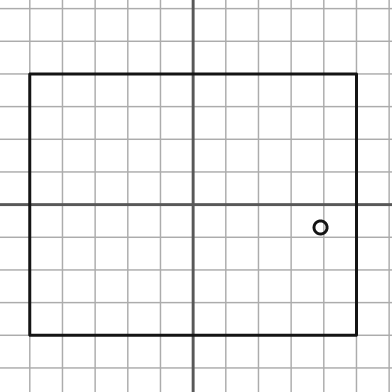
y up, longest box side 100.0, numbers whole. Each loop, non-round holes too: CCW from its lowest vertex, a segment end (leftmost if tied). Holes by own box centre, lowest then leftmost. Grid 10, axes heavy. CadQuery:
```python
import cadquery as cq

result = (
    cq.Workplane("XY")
    .moveTo(-50.0, -40.0)
    .lineTo(50.0, -40.0)
    .lineTo(50.0, 40.0)
    .lineTo(-50.0, 40.0)
    .close()
    .moveTo(39.0, -7.0)
    .circle(2.0)
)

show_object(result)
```